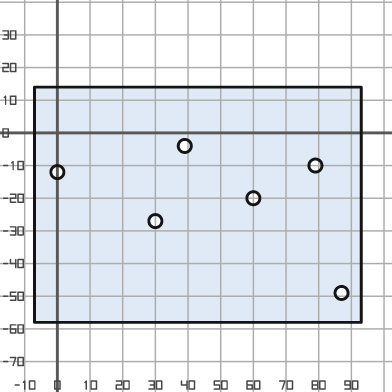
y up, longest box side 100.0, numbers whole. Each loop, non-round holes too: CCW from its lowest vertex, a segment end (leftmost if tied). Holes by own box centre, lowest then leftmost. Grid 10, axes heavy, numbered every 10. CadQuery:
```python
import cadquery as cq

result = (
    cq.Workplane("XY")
    .moveTo(-7.0, -58.0)
    .lineTo(93.0, -58.0)
    .lineTo(93.0, 14.0)
    .lineTo(-7.0, 14.0)
    .close()
    .moveTo(87.0, -49.0)
    .circle(2.0)
    .moveTo(30.0, -27.0)
    .circle(2.0)
    .moveTo(60.0, -20.0)
    .circle(2.0)
    .moveTo(0.0, -12.0)
    .circle(2.0)
    .moveTo(79.0, -10.0)
    .circle(2.0)
    .moveTo(39.0, -4.0)
    .circle(2.0)
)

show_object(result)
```